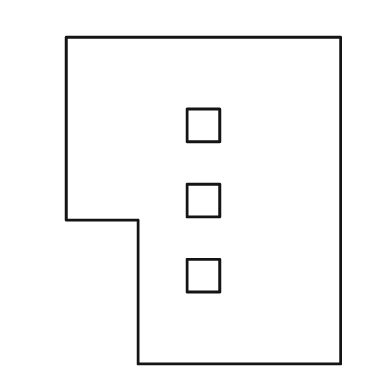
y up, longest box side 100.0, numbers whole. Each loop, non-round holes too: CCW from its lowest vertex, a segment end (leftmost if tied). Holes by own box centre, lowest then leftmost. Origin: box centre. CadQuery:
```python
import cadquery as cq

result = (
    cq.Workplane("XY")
    .moveTo(-20.0, -50.0)
    .lineTo(42.0, -50.0)
    .lineTo(42.0, 50.0)
    .lineTo(-42.0, 50.0)
    .lineTo(-42.0, -6.0)
    .lineTo(-20.0, -6.0)
    .close()
    .moveTo(-5.0, -28.0)
    .lineTo(5.0, -28.0)
    .lineTo(5.0, -18.0)
    .lineTo(-5.0, -18.0)
    .close()
    .moveTo(-5.0, -5.0)
    .lineTo(5.0, -5.0)
    .lineTo(5.0, 5.0)
    .lineTo(-5.0, 5.0)
    .close()
    .moveTo(-5.0, 18.0)
    .lineTo(5.0, 18.0)
    .lineTo(5.0, 28.0)
    .lineTo(-5.0, 28.0)
    .close()
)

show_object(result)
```